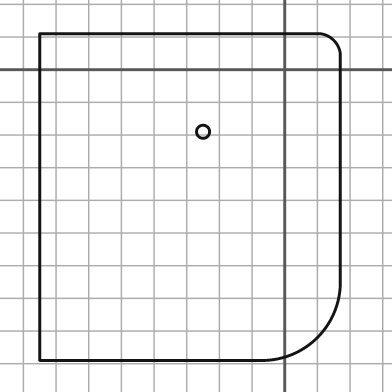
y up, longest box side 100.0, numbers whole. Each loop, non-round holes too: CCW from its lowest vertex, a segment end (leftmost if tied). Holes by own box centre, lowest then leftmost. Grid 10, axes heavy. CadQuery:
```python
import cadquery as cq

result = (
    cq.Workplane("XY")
    .moveTo(-75.0, -89.0)
    .lineTo(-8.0, -89.0)
    .threePointArc((10.0, -82.0), (17.0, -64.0))
    .lineTo(17.0, 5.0)
    .threePointArc((15.0, 9.0), (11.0, 11.0))
    .lineTo(-75.0, 11.0)
    .close()
    .moveTo(-25.0, -19.0)
    .circle(2.0)
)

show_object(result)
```